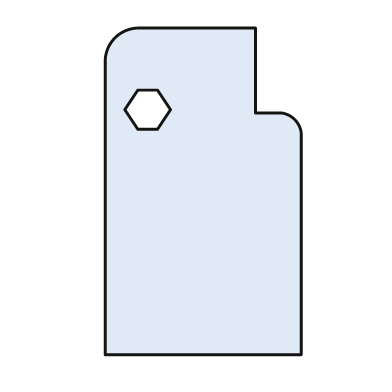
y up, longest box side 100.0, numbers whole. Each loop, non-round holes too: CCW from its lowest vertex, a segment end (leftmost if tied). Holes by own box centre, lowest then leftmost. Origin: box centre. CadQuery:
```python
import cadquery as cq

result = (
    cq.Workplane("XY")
    .moveTo(-30.0, -50.0)
    .lineTo(30.0, -50.0)
    .lineTo(30.0, 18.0)
    .threePointArc((28.0, 22.0), (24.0, 24.0))
    .lineTo(16.0, 24.0)
    .lineTo(16.0, 50.0)
    .lineTo(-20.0, 50.0)
    .threePointArc((-27.0, 47.0), (-30.0, 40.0))
    .close()
    .moveTo(-20.0, 19.0)
    .lineTo(-14.0, 19.0)
    .lineTo(-10.0, 25.0)
    .lineTo(-14.0, 31.0)
    .lineTo(-20.0, 31.0)
    .lineTo(-24.0, 25.0)
    .close()
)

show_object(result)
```